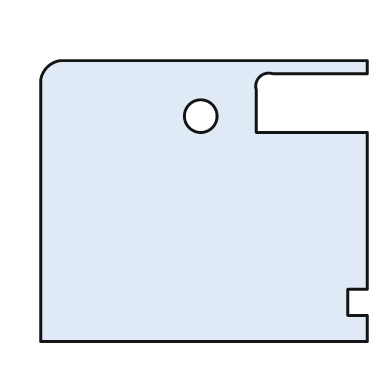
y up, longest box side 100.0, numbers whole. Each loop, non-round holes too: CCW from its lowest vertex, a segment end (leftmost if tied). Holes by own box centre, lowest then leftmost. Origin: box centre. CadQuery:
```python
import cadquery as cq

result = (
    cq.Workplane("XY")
    .moveTo(-50.0, -43.0)
    .lineTo(50.0, -43.0)
    .lineTo(50.0, -35.0)
    .lineTo(44.0, -35.0)
    .lineTo(44.0, -27.0)
    .lineTo(50.0, -27.0)
    .lineTo(50.0, 21.0)
    .lineTo(16.0, 21.0)
    .lineTo(16.0, 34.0)
    .threePointArc((17.0, 38.0), (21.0, 39.0))
    .lineTo(50.0, 39.0)
    .lineTo(50.0, 43.0)
    .lineTo(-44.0, 43.0)
    .threePointArc((-48.0, 41.0), (-50.0, 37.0))
    .close()
    .moveTo(-1.0, 26.0)
    .circle(5.0)
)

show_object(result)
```